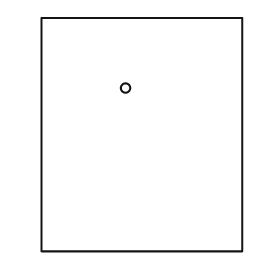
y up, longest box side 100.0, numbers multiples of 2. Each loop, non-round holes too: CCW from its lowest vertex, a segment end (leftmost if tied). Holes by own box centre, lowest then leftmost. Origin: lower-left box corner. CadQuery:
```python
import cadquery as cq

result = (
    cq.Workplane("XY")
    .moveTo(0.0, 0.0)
    .lineTo(86.0, 0.0)
    .lineTo(86.0, 100.0)
    .lineTo(0.0, 100.0)
    .close()
    .moveTo(36.0, 70.0)
    .circle(2.0)
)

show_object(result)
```